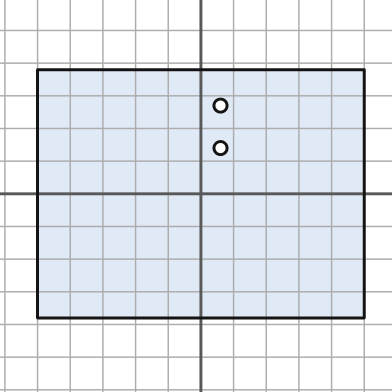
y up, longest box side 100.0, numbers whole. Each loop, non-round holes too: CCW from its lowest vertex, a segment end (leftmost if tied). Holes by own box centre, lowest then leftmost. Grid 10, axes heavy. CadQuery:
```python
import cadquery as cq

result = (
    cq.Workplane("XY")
    .moveTo(-50.0, -38.0)
    .lineTo(50.0, -38.0)
    .lineTo(50.0, 38.0)
    .lineTo(-50.0, 38.0)
    .close()
    .moveTo(6.0, 14.0)
    .circle(2.0)
    .moveTo(6.0, 27.0)
    .circle(2.0)
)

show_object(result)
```